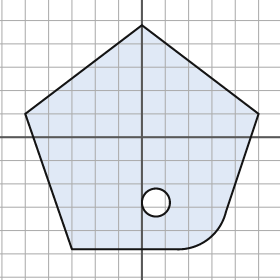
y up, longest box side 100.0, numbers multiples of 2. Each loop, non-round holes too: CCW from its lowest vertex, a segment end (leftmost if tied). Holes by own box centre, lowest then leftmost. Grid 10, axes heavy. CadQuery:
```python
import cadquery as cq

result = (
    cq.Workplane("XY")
    .moveTo(-30.0, -48.0)
    .lineTo(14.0, -48.0)
    .threePointArc((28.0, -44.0), (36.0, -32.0))
    .lineTo(50.0, 10.0)
    .lineTo(0.0, 48.0)
    .lineTo(-50.0, 10.0)
    .close()
    .moveTo(6.0, -28.0)
    .circle(6.0)
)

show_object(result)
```